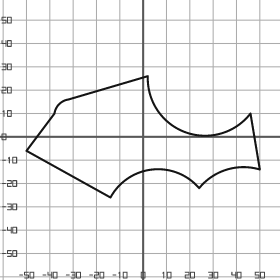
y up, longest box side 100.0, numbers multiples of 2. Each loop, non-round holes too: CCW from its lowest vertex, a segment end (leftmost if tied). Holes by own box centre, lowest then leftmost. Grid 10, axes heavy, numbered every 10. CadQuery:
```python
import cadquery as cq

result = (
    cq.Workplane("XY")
    .moveTo(-14.0, -26.0)
    .threePointArc((4.0, -14.0), (24.0, -22.0))
    .threePointArc((36.0, -14.0), (50.0, -14.0))
    .lineTo(46.0, 10.0)
    .threePointArc((18.0, 2.0), (2.0, 26.0))
    .lineTo(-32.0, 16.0)
    .threePointArc((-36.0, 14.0), (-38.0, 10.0))
    .lineTo(-50.0, -6.0)
    .close()
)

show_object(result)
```